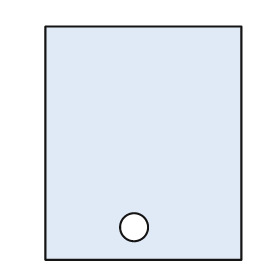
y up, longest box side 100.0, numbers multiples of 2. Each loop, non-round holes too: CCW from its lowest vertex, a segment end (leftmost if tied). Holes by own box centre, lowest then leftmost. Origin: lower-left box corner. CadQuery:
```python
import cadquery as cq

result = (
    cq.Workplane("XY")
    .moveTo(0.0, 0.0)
    .lineTo(84.0, 0.0)
    .lineTo(84.0, 100.0)
    .lineTo(0.0, 100.0)
    .close()
    .moveTo(38.0, 14.0)
    .circle(6.0)
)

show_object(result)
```